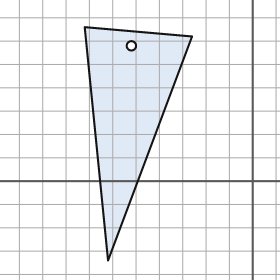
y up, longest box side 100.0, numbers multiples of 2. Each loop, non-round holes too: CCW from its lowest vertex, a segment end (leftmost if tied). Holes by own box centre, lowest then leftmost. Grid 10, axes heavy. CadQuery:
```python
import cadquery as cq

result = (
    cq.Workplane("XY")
    .moveTo(-62.0, -34.0)
    .lineTo(-26.0, 62.0)
    .lineTo(-72.0, 66.0)
    .close()
    .moveTo(-52.0, 58.0)
    .circle(2.0)
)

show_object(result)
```